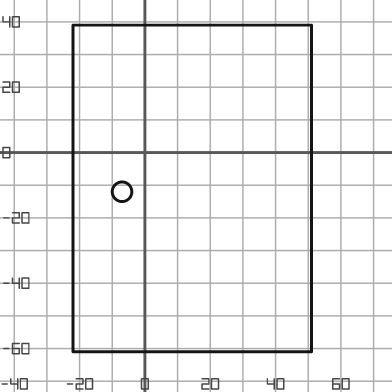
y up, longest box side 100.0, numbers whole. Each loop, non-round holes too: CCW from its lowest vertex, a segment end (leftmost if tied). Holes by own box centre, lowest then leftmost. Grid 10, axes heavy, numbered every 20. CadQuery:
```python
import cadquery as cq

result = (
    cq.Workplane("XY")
    .moveTo(-22.0, -61.0)
    .lineTo(51.0, -61.0)
    .lineTo(51.0, 39.0)
    .lineTo(-22.0, 39.0)
    .close()
    .moveTo(-7.0, -12.0)
    .circle(3.0)
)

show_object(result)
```